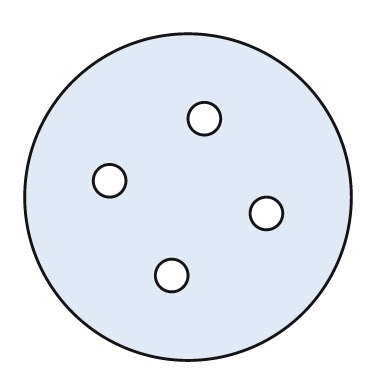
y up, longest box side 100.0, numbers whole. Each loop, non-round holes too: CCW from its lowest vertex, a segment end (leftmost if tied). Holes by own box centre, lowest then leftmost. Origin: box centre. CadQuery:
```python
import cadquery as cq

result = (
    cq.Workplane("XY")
    .moveTo(0.0, 0.0)
    .circle(50.0)
    .moveTo(-5.0, -24.0)
    .circle(5.0)
    .moveTo(24.0, -5.0)
    .circle(5.0)
    .moveTo(-24.0, 5.0)
    .circle(5.0)
    .moveTo(5.0, 24.0)
    .circle(5.0)
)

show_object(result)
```